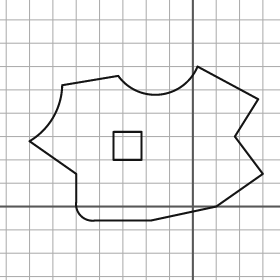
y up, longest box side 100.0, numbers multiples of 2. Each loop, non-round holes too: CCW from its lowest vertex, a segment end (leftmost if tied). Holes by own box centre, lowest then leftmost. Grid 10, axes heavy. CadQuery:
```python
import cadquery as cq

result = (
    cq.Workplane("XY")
    .moveTo(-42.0, -6.0)
    .lineTo(-18.0, -6.0)
    .lineTo(10.0, 0.0)
    .lineTo(30.0, 14.0)
    .lineTo(18.0, 30.0)
    .lineTo(28.0, 46.0)
    .lineTo(2.0, 60.0)
    .threePointArc((-14.0, 48.0), (-32.0, 56.0))
    .lineTo(-56.0, 52.0)
    .threePointArc((-60.0, 38.0), (-70.0, 28.0))
    .lineTo(-50.0, 14.0)
    .lineTo(-50.0, 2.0)
    .threePointArc((-48.0, -4.0), (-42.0, -6.0))
    .close()
    .moveTo(-34.0, 20.0)
    .lineTo(-22.0, 20.0)
    .lineTo(-22.0, 32.0)
    .lineTo(-34.0, 32.0)
    .close()
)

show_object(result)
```